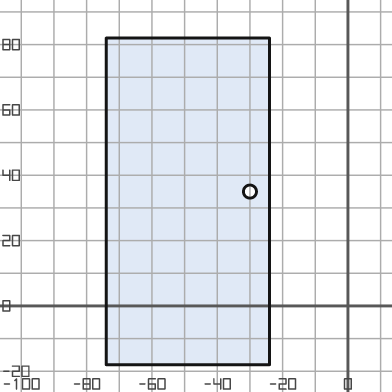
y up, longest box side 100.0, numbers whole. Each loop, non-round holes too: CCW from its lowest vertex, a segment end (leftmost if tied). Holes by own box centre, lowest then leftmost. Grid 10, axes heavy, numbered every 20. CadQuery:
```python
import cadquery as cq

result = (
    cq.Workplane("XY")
    .moveTo(-74.0, -18.0)
    .lineTo(-24.0, -18.0)
    .lineTo(-24.0, 82.0)
    .lineTo(-74.0, 82.0)
    .close()
    .moveTo(-30.0, 35.0)
    .circle(2.0)
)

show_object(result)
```